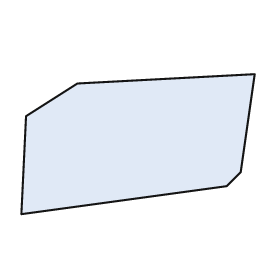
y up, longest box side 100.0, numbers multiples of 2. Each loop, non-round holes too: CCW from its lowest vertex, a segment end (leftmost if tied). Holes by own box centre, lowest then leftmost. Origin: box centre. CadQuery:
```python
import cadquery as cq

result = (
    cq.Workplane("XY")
    .moveTo(-50.0, -30.0)
    .lineTo(38.0, -18.0)
    .lineTo(44.0, -12.0)
    .lineTo(50.0, 30.0)
    .lineTo(-26.0, 26.0)
    .lineTo(-48.0, 12.0)
    .close()
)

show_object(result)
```